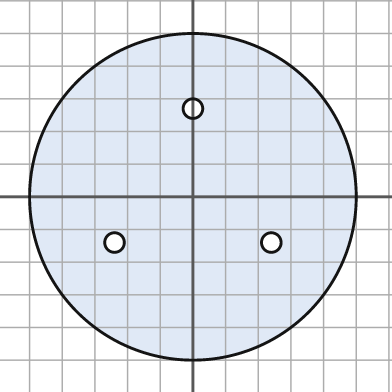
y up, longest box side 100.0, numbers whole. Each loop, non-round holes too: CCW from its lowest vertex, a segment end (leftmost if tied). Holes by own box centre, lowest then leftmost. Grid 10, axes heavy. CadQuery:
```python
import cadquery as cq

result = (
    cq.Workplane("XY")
    .moveTo(0.0, 0.0)
    .circle(50.0)
    .moveTo(-24.0, -14.0)
    .circle(3.0)
    .moveTo(24.0, -14.0)
    .circle(3.0)
    .moveTo(0.0, 27.0)
    .circle(3.0)
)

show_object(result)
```